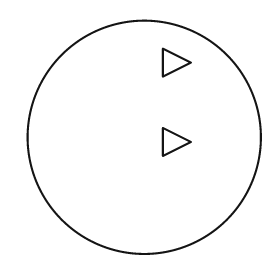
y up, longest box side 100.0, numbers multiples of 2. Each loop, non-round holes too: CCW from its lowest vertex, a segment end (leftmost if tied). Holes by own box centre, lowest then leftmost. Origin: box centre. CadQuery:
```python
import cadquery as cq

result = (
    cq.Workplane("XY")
    .moveTo(0.0, 0.0)
    .circle(50.0)
    .moveTo(8.0, -8.0)
    .lineTo(20.0, -2.0)
    .lineTo(8.0, 4.0)
    .close()
    .moveTo(8.0, 26.0)
    .lineTo(20.0, 32.0)
    .lineTo(8.0, 38.0)
    .close()
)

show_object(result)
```